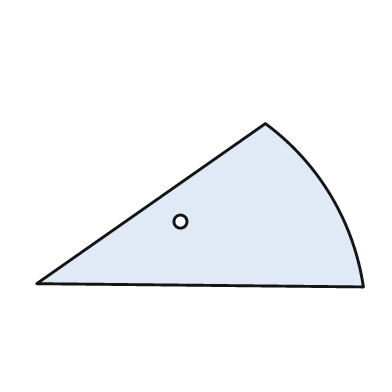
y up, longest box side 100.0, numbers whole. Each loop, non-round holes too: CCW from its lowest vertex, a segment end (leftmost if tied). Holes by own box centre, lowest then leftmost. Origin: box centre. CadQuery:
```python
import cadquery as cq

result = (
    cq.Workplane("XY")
    .moveTo(50.0, -25.0)
    .threePointArc((40.0, 3.0), (20.0, 25.0))
    .lineTo(-50.0, -24.0)
    .close()
    .moveTo(-6.0, -5.0)
    .circle(2.0)
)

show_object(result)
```